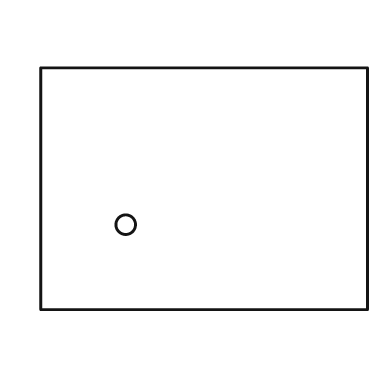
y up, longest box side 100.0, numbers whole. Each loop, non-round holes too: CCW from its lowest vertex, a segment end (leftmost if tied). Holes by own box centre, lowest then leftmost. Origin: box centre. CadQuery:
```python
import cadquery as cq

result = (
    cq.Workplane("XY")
    .moveTo(-50.0, -37.0)
    .lineTo(50.0, -37.0)
    .lineTo(50.0, 37.0)
    .lineTo(-50.0, 37.0)
    .close()
    .moveTo(-24.0, -11.0)
    .circle(3.0)
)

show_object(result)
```